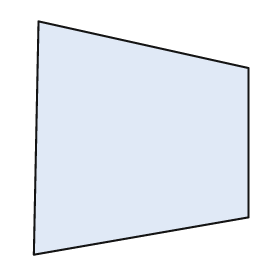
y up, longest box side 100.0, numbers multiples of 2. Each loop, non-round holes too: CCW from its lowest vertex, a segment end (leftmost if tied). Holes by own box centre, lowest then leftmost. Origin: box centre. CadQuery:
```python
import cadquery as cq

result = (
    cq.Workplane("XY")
    .moveTo(-46.0, -50.0)
    .lineTo(46.0, -34.0)
    .lineTo(46.0, 30.0)
    .lineTo(-44.0, 50.0)
    .close()
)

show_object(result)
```